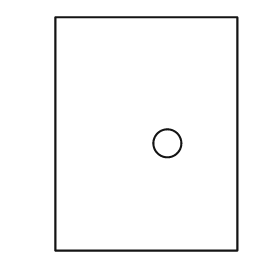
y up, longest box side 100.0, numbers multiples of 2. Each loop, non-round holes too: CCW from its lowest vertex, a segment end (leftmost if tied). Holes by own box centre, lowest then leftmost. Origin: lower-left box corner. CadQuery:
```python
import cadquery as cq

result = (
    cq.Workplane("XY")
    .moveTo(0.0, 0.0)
    .lineTo(78.0, 0.0)
    .lineTo(78.0, 100.0)
    .lineTo(0.0, 100.0)
    .close()
    .moveTo(48.0, 46.0)
    .circle(6.0)
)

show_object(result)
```